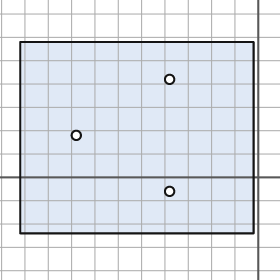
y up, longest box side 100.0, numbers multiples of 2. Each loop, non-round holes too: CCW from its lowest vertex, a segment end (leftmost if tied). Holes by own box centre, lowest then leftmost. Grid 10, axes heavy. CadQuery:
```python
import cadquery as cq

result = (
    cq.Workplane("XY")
    .moveTo(-102.0, -24.0)
    .lineTo(-2.0, -24.0)
    .lineTo(-2.0, 58.0)
    .lineTo(-102.0, 58.0)
    .close()
    .moveTo(-38.0, -6.0)
    .circle(2.0)
    .moveTo(-78.0, 18.0)
    .circle(2.0)
    .moveTo(-38.0, 42.0)
    .circle(2.0)
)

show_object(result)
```